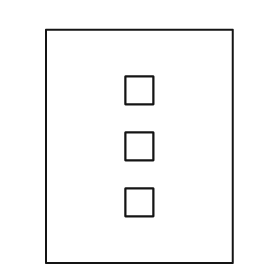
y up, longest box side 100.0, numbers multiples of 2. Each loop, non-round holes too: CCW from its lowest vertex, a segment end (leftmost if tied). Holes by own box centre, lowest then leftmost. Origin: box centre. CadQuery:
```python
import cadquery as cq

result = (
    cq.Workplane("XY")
    .moveTo(-40.0, -50.0)
    .lineTo(40.0, -50.0)
    .lineTo(40.0, 50.0)
    .lineTo(-40.0, 50.0)
    .close()
    .moveTo(-6.0, -30.0)
    .lineTo(6.0, -30.0)
    .lineTo(6.0, -18.0)
    .lineTo(-6.0, -18.0)
    .close()
    .moveTo(-6.0, -6.0)
    .lineTo(6.0, -6.0)
    .lineTo(6.0, 6.0)
    .lineTo(-6.0, 6.0)
    .close()
    .moveTo(-6.0, 18.0)
    .lineTo(6.0, 18.0)
    .lineTo(6.0, 30.0)
    .lineTo(-6.0, 30.0)
    .close()
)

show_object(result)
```